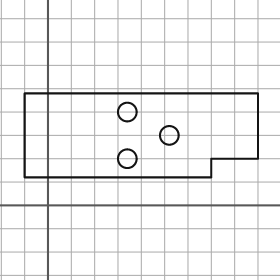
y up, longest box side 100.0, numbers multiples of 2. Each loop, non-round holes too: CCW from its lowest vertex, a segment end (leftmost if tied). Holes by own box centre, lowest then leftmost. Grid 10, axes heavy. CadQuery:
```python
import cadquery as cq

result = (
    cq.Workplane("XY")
    .moveTo(-10.0, 12.0)
    .lineTo(70.0, 12.0)
    .lineTo(70.0, 20.0)
    .lineTo(90.0, 20.0)
    .lineTo(90.0, 48.0)
    .lineTo(-10.0, 48.0)
    .close()
    .moveTo(34.0, 20.0)
    .circle(4.0)
    .moveTo(52.0, 30.0)
    .circle(4.0)
    .moveTo(34.0, 40.0)
    .circle(4.0)
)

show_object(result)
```